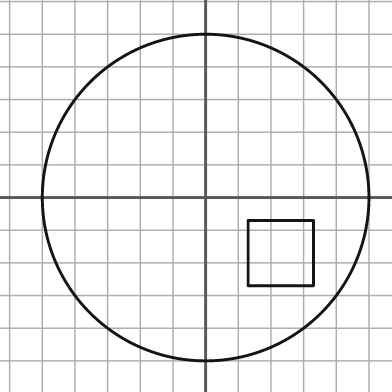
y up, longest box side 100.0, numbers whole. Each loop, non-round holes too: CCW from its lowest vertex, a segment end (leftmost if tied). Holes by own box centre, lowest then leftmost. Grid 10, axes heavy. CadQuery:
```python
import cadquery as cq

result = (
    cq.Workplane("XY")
    .moveTo(0.0, 0.0)
    .circle(50.0)
    .moveTo(13.0, -27.0)
    .lineTo(33.0, -27.0)
    .lineTo(33.0, -7.0)
    .lineTo(13.0, -7.0)
    .close()
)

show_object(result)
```